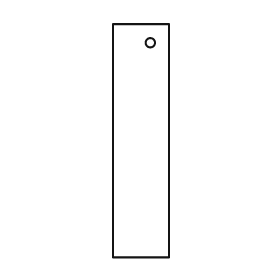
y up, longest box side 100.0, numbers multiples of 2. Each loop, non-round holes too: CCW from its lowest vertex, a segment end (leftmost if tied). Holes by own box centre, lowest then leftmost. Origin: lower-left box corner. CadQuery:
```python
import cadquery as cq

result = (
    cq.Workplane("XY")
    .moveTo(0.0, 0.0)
    .lineTo(24.0, 0.0)
    .lineTo(24.0, 100.0)
    .lineTo(0.0, 100.0)
    .close()
    .moveTo(16.0, 92.0)
    .circle(2.0)
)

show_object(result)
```